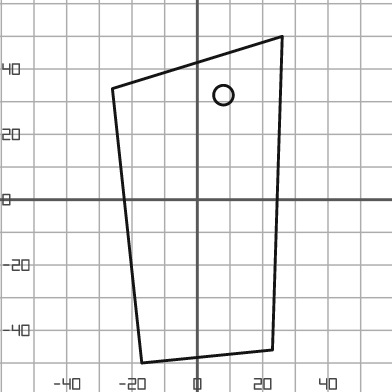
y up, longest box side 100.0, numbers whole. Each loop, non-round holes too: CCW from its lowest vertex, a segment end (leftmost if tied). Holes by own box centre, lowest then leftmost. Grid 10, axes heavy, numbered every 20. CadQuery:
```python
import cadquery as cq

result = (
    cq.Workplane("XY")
    .moveTo(-17.0, -50.0)
    .lineTo(23.0, -46.0)
    .lineTo(26.0, 50.0)
    .lineTo(-26.0, 34.0)
    .close()
    .moveTo(8.0, 32.0)
    .circle(3.0)
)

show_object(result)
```